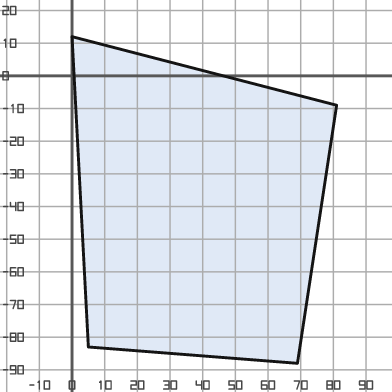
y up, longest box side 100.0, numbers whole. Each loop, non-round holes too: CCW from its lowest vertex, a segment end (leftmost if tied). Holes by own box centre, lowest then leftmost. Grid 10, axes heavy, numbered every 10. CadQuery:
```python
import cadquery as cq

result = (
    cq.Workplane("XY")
    .moveTo(69.0, -88.0)
    .lineTo(81.0, -9.0)
    .lineTo(0.0, 12.0)
    .lineTo(5.0, -83.0)
    .close()
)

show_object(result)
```